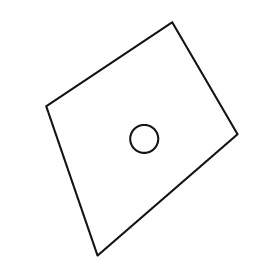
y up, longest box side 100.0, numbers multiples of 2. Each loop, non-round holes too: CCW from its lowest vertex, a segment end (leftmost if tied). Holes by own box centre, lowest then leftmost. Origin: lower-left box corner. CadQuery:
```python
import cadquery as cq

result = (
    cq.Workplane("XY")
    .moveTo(22.0, 0.0)
    .lineTo(82.0, 52.0)
    .lineTo(54.0, 100.0)
    .lineTo(0.0, 64.0)
    .close()
    .moveTo(42.0, 50.0)
    .circle(6.0)
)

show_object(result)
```